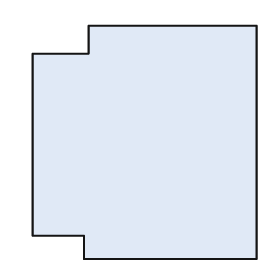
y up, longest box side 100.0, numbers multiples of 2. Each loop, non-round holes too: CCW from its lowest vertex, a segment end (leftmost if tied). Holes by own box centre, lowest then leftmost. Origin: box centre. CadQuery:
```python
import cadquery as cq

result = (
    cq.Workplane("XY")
    .moveTo(-26.0, -50.0)
    .lineTo(48.0, -50.0)
    .lineTo(48.0, 50.0)
    .lineTo(-24.0, 50.0)
    .lineTo(-24.0, 38.0)
    .lineTo(-48.0, 38.0)
    .lineTo(-48.0, -40.0)
    .lineTo(-26.0, -40.0)
    .close()
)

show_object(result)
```